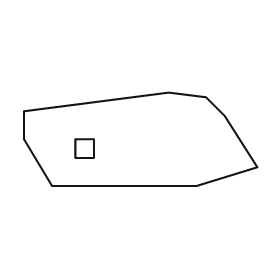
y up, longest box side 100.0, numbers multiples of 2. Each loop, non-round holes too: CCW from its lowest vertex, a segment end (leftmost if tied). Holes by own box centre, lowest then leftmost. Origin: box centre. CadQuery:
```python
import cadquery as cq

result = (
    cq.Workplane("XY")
    .moveTo(-38.0, -20.0)
    .lineTo(24.0, -20.0)
    .lineTo(50.0, -12.0)
    .lineTo(36.0, 10.0)
    .lineTo(28.0, 18.0)
    .lineTo(12.0, 20.0)
    .lineTo(-50.0, 12.0)
    .lineTo(-50.0, 0.0)
    .close()
    .moveTo(-28.0, -8.0)
    .lineTo(-20.0, -8.0)
    .lineTo(-20.0, 0.0)
    .lineTo(-28.0, 0.0)
    .close()
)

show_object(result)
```